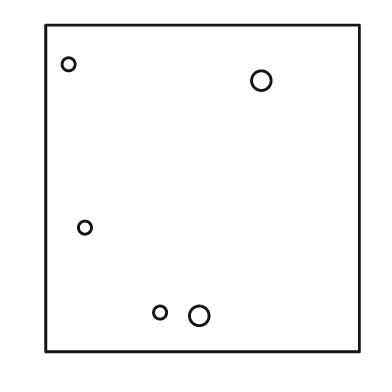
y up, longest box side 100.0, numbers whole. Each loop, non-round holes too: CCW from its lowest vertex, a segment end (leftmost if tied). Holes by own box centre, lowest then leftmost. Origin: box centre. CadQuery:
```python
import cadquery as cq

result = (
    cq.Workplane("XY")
    .moveTo(-48.0, -50.0)
    .lineTo(48.0, -50.0)
    .lineTo(48.0, 50.0)
    .lineTo(-48.0, 50.0)
    .close()
    .moveTo(-1.0, -39.0)
    .circle(3.0)
    .moveTo(-13.0, -38.0)
    .circle(2.0)
    .moveTo(-36.0, -12.0)
    .circle(2.0)
    .moveTo(18.0, 33.0)
    .circle(3.0)
    .moveTo(-41.0, 38.0)
    .circle(2.0)
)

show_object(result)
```